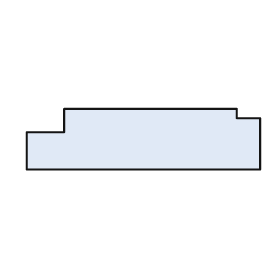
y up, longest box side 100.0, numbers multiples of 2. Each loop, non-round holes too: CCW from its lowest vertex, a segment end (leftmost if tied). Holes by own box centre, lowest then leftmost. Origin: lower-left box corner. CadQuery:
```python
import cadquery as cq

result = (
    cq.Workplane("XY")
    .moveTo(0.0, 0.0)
    .lineTo(100.0, 0.0)
    .lineTo(100.0, 22.0)
    .lineTo(90.0, 22.0)
    .lineTo(90.0, 26.0)
    .lineTo(16.0, 26.0)
    .lineTo(16.0, 16.0)
    .lineTo(0.0, 16.0)
    .close()
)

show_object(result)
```